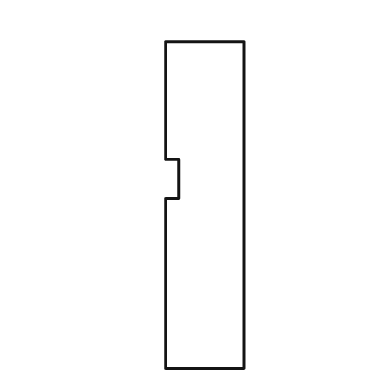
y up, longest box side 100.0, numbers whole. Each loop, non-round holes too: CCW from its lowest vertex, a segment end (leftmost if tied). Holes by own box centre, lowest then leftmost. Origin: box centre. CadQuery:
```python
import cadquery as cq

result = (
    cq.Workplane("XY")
    .moveTo(-12.0, -50.0)
    .lineTo(12.0, -50.0)
    .lineTo(12.0, 50.0)
    .lineTo(-12.0, 50.0)
    .lineTo(-12.0, 14.0)
    .lineTo(-8.0, 14.0)
    .lineTo(-8.0, 2.0)
    .lineTo(-12.0, 2.0)
    .close()
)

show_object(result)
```